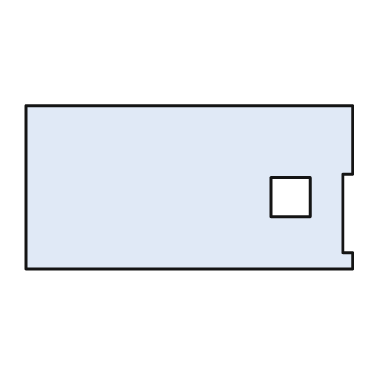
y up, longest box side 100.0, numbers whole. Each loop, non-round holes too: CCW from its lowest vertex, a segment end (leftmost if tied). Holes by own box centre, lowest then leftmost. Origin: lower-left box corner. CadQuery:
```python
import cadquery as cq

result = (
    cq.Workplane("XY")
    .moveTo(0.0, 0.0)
    .lineTo(100.0, 0.0)
    .lineTo(100.0, 5.0)
    .lineTo(97.0, 5.0)
    .lineTo(97.0, 29.0)
    .lineTo(100.0, 29.0)
    .lineTo(100.0, 50.0)
    .lineTo(0.0, 50.0)
    .close()
    .moveTo(75.0, 16.0)
    .lineTo(87.0, 16.0)
    .lineTo(87.0, 28.0)
    .lineTo(75.0, 28.0)
    .close()
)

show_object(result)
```